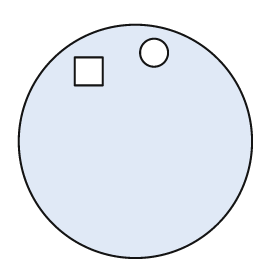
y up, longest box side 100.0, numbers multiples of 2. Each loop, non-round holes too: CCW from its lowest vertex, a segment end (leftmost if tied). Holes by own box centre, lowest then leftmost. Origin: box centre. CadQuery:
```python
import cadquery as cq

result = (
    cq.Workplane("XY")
    .moveTo(0.0, 0.0)
    .circle(50.0)
    .moveTo(-26.0, 24.0)
    .lineTo(-14.0, 24.0)
    .lineTo(-14.0, 36.0)
    .lineTo(-26.0, 36.0)
    .close()
    .moveTo(8.0, 38.0)
    .circle(6.0)
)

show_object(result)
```